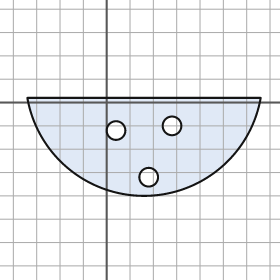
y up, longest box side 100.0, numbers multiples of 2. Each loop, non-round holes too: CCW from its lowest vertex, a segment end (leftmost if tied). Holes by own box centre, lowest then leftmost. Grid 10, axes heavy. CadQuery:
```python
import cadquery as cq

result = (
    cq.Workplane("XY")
    .moveTo(-34.0, 2.0)
    .threePointArc((16.0, -40.0), (66.0, 2.0))
    .close()
    .moveTo(18.0, -32.0)
    .circle(4.0)
    .moveTo(4.0, -12.0)
    .circle(4.0)
    .moveTo(28.0, -10.0)
    .circle(4.0)
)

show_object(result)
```